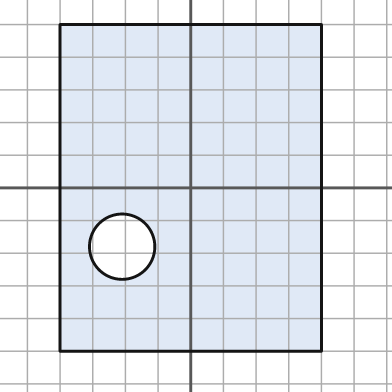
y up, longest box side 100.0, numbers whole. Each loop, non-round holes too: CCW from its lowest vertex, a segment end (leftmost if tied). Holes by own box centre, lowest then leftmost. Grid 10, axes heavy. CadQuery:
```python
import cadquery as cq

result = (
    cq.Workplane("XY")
    .moveTo(-40.0, -50.0)
    .lineTo(40.0, -50.0)
    .lineTo(40.0, 50.0)
    .lineTo(-40.0, 50.0)
    .close()
    .moveTo(-21.0, -18.0)
    .circle(10.0)
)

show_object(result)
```